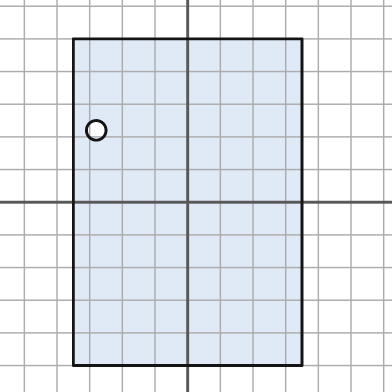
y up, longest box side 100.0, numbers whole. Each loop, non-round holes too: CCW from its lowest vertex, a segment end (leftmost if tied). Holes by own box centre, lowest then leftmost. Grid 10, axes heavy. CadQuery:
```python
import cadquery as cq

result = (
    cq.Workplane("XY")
    .moveTo(-35.0, -50.0)
    .lineTo(35.0, -50.0)
    .lineTo(35.0, 50.0)
    .lineTo(-35.0, 50.0)
    .close()
    .moveTo(-28.0, 22.0)
    .circle(3.0)
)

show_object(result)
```